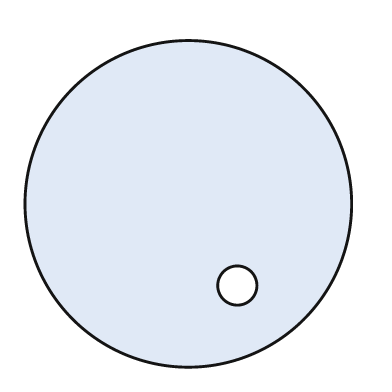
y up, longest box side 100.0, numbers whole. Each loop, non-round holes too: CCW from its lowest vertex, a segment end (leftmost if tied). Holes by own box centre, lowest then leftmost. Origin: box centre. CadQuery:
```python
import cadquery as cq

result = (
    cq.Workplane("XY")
    .moveTo(0.0, 0.0)
    .circle(50.0)
    .moveTo(15.0, -25.0)
    .circle(6.0)
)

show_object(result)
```